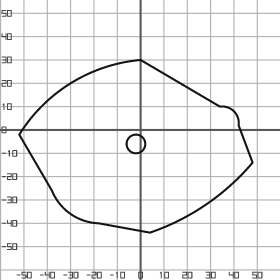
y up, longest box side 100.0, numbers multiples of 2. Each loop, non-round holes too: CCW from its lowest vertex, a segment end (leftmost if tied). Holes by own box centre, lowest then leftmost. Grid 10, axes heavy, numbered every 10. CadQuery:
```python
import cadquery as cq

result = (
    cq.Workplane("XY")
    .moveTo(4.0, -44.0)
    .threePointArc((28.0, -32.0), (48.0, -14.0))
    .lineTo(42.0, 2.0)
    .threePointArc((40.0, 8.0), (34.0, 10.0))
    .lineTo(0.0, 30.0)
    .threePointArc((-30.0, 20.0), (-52.0, -2.0))
    .lineTo(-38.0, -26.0)
    .threePointArc((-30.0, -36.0), (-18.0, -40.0))
    .close()
    .moveTo(-2.0, -6.0)
    .circle(4.0)
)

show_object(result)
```